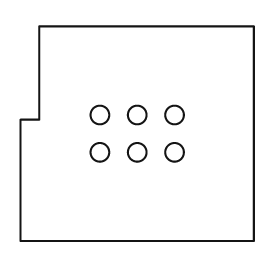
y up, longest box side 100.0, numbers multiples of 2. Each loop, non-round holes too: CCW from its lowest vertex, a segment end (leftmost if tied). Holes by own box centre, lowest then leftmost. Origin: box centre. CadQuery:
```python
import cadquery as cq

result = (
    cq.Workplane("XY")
    .moveTo(-50.0, -46.0)
    .lineTo(50.0, -46.0)
    .lineTo(50.0, 46.0)
    .lineTo(-42.0, 46.0)
    .lineTo(-42.0, 6.0)
    .lineTo(-50.0, 6.0)
    .close()
    .moveTo(-16.0, -8.0)
    .circle(4.0)
    .moveTo(0.0, -8.0)
    .circle(4.0)
    .moveTo(16.0, -8.0)
    .circle(4.0)
    .moveTo(-16.0, 8.0)
    .circle(4.0)
    .moveTo(0.0, 8.0)
    .circle(4.0)
    .moveTo(16.0, 8.0)
    .circle(4.0)
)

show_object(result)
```